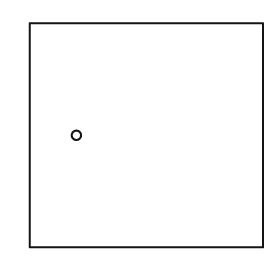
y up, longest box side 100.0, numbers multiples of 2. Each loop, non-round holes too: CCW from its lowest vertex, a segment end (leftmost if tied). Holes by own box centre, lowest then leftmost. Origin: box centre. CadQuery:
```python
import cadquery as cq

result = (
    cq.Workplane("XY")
    .moveTo(-50.0, -48.0)
    .lineTo(50.0, -48.0)
    .lineTo(50.0, 48.0)
    .lineTo(-50.0, 48.0)
    .close()
    .moveTo(-30.0, 0.0)
    .circle(2.0)
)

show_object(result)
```